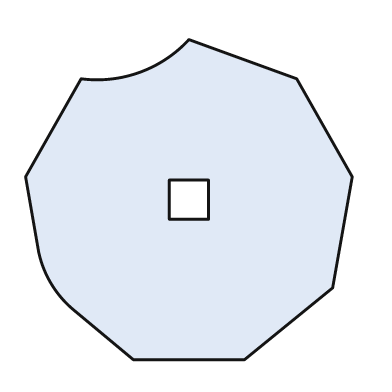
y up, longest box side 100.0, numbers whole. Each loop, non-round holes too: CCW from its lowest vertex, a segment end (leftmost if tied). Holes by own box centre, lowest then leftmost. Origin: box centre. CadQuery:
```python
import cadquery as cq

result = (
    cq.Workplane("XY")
    .moveTo(-17.0, -49.0)
    .lineTo(17.0, -49.0)
    .lineTo(44.0, -27.0)
    .lineTo(50.0, 7.0)
    .lineTo(33.0, 37.0)
    .lineTo(0.0, 49.0)
    .threePointArc((-15.0, 39.0), (-33.0, 37.0))
    .lineTo(-50.0, 7.0)
    .lineTo(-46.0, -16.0)
    .threePointArc((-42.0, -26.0), (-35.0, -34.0))
    .close()
    .moveTo(-6.0, -6.0)
    .lineTo(6.0, -6.0)
    .lineTo(6.0, 6.0)
    .lineTo(-6.0, 6.0)
    .close()
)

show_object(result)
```